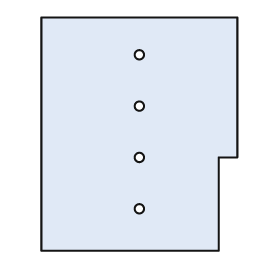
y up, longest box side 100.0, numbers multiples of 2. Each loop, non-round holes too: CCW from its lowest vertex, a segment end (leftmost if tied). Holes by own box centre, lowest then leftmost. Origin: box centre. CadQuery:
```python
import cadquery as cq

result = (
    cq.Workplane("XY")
    .moveTo(-42.0, -50.0)
    .lineTo(34.0, -50.0)
    .lineTo(34.0, -10.0)
    .lineTo(42.0, -10.0)
    .lineTo(42.0, 50.0)
    .lineTo(-42.0, 50.0)
    .close()
    .moveTo(0.0, -32.0)
    .circle(2.0)
    .moveTo(0.0, -10.0)
    .circle(2.0)
    .moveTo(0.0, 12.0)
    .circle(2.0)
    .moveTo(0.0, 34.0)
    .circle(2.0)
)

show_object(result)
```